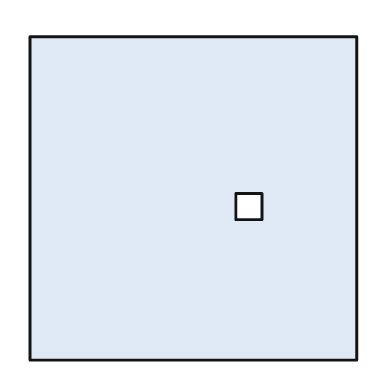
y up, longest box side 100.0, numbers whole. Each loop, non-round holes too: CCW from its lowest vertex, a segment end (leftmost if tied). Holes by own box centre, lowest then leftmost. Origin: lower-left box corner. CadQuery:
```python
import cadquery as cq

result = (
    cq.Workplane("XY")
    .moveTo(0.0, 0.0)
    .lineTo(100.0, 0.0)
    .lineTo(100.0, 99.0)
    .lineTo(0.0, 99.0)
    .close()
    .moveTo(63.0, 43.0)
    .lineTo(71.0, 43.0)
    .lineTo(71.0, 51.0)
    .lineTo(63.0, 51.0)
    .close()
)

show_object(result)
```